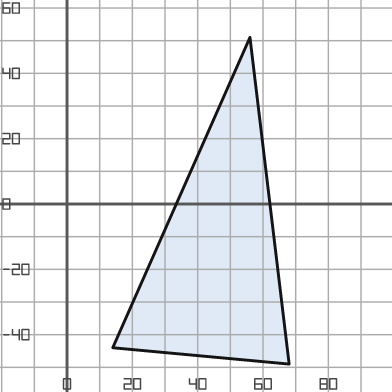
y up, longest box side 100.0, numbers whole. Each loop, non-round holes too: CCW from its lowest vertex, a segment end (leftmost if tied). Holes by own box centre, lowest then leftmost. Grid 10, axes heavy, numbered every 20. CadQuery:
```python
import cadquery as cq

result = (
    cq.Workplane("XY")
    .moveTo(68.0, -49.0)
    .lineTo(56.0, 51.0)
    .lineTo(14.0, -44.0)
    .close()
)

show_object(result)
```